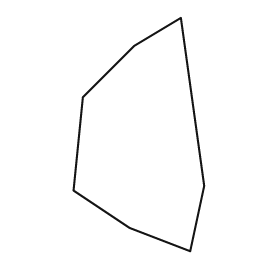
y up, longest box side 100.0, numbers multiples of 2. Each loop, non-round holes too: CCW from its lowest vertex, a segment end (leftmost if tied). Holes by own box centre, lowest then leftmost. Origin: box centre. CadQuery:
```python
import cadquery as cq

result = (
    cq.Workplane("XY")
    .moveTo(22.0, -50.0)
    .lineTo(28.0, -22.0)
    .lineTo(18.0, 50.0)
    .lineTo(-2.0, 38.0)
    .lineTo(-24.0, 16.0)
    .lineTo(-28.0, -24.0)
    .lineTo(-4.0, -40.0)
    .close()
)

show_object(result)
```